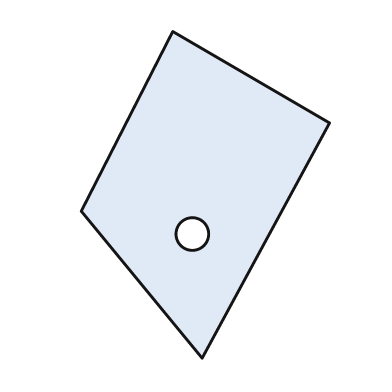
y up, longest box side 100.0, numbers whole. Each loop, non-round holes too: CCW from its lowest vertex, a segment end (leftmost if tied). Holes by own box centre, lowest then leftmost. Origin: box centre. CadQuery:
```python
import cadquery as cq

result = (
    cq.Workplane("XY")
    .moveTo(-1.0, -50.0)
    .lineTo(38.0, 22.0)
    .lineTo(-10.0, 50.0)
    .lineTo(-38.0, -5.0)
    .close()
    .moveTo(-4.0, -12.0)
    .circle(5.0)
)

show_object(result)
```